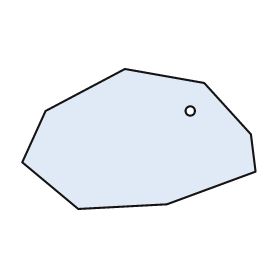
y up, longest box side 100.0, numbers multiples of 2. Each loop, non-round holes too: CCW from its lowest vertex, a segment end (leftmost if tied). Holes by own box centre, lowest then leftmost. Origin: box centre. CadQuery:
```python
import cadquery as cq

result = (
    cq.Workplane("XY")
    .moveTo(-26.0, -30.0)
    .lineTo(12.0, -28.0)
    .lineTo(50.0, -14.0)
    .lineTo(48.0, 2.0)
    .lineTo(28.0, 24.0)
    .lineTo(-6.0, 30.0)
    .lineTo(-40.0, 12.0)
    .lineTo(-50.0, -10.0)
    .close()
    .moveTo(22.0, 12.0)
    .circle(2.0)
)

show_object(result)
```